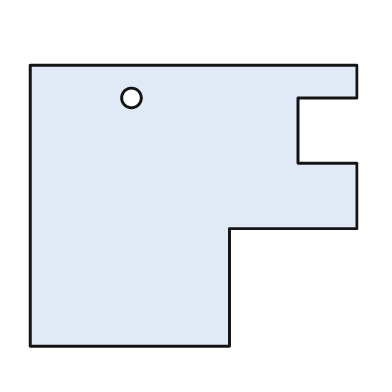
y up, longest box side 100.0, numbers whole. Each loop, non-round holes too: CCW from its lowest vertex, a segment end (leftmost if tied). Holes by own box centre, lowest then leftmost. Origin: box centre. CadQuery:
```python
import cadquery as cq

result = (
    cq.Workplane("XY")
    .moveTo(-50.0, -43.0)
    .lineTo(11.0, -43.0)
    .lineTo(11.0, -7.0)
    .lineTo(50.0, -7.0)
    .lineTo(50.0, 13.0)
    .lineTo(32.0, 13.0)
    .lineTo(32.0, 33.0)
    .lineTo(50.0, 33.0)
    .lineTo(50.0, 43.0)
    .lineTo(-50.0, 43.0)
    .close()
    .moveTo(-19.0, 33.0)
    .circle(3.0)
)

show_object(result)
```